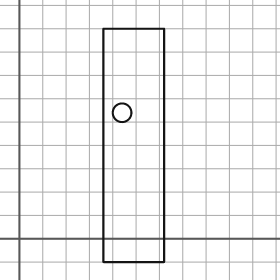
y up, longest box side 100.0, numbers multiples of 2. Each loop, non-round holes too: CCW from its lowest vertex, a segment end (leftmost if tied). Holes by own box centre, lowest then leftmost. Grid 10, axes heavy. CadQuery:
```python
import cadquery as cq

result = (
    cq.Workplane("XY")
    .moveTo(36.0, -10.0)
    .lineTo(62.0, -10.0)
    .lineTo(62.0, 90.0)
    .lineTo(36.0, 90.0)
    .close()
    .moveTo(44.0, 54.0)
    .circle(4.0)
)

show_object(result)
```